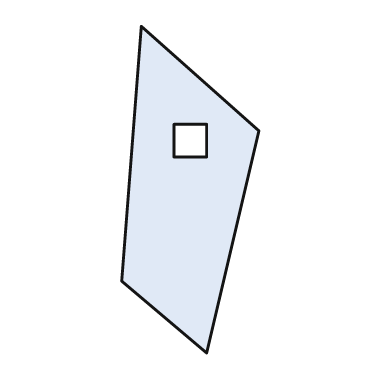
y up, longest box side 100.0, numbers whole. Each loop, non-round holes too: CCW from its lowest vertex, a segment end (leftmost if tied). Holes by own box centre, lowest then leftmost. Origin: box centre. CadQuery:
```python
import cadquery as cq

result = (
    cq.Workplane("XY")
    .moveTo(5.0, -50.0)
    .lineTo(21.0, 18.0)
    .lineTo(-15.0, 50.0)
    .lineTo(-21.0, -28.0)
    .close()
    .moveTo(-5.0, 10.0)
    .lineTo(5.0, 10.0)
    .lineTo(5.0, 20.0)
    .lineTo(-5.0, 20.0)
    .close()
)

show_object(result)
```